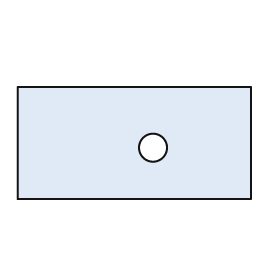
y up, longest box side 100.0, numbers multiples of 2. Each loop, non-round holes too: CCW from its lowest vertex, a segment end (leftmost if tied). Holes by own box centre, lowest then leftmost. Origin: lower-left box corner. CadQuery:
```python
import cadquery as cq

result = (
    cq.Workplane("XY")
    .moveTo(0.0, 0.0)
    .lineTo(100.0, 0.0)
    .lineTo(100.0, 48.0)
    .lineTo(0.0, 48.0)
    .close()
    .moveTo(58.0, 22.0)
    .circle(6.0)
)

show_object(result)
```